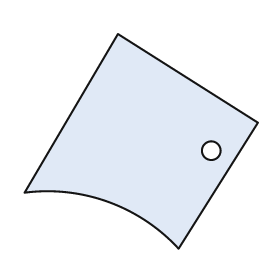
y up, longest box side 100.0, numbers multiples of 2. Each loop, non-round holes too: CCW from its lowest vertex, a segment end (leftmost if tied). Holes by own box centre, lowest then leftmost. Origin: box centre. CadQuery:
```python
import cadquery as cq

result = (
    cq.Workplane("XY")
    .moveTo(16.0, -46.0)
    .lineTo(50.0, 8.0)
    .lineTo(-10.0, 46.0)
    .lineTo(-50.0, -22.0)
    .threePointArc((-14.0, -26.0), (16.0, -46.0))
    .close()
    .moveTo(30.0, -4.0)
    .circle(4.0)
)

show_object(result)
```